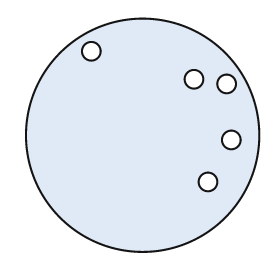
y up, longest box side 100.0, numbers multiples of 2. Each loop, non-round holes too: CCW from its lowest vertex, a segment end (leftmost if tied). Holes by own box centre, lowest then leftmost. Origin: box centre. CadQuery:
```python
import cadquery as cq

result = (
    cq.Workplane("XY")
    .moveTo(0.0, 0.0)
    .circle(50.0)
    .moveTo(28.0, -20.0)
    .circle(4.0)
    .moveTo(38.0, -2.0)
    .circle(4.0)
    .moveTo(36.0, 22.0)
    .circle(4.0)
    .moveTo(22.0, 24.0)
    .circle(4.0)
    .moveTo(-22.0, 36.0)
    .circle(4.0)
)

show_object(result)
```